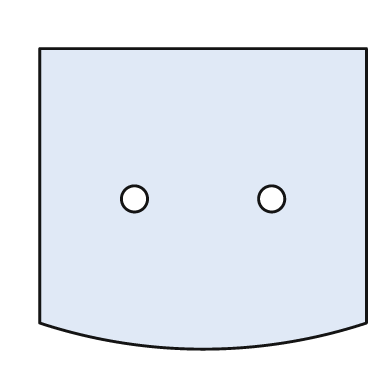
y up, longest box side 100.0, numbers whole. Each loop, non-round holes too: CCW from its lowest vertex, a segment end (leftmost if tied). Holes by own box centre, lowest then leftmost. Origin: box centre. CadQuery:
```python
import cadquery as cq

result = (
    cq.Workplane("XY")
    .moveTo(-50.0, -38.0)
    .threePointArc((0.0, -46.0), (50.0, -38.0))
    .lineTo(50.0, 46.0)
    .lineTo(-50.0, 46.0)
    .close()
    .moveTo(-21.0, 0.0)
    .circle(4.0)
    .moveTo(21.0, 0.0)
    .circle(4.0)
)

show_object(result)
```